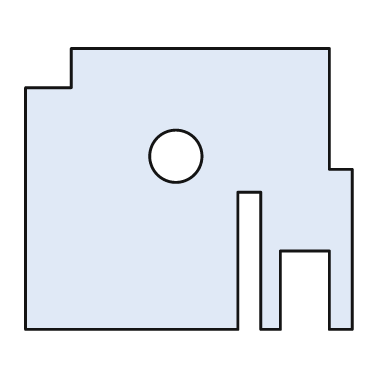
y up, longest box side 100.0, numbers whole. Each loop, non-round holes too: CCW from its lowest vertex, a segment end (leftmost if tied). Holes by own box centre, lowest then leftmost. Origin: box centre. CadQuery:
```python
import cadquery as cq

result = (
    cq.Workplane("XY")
    .moveTo(-50.0, -43.0)
    .lineTo(15.0, -43.0)
    .lineTo(15.0, -1.0)
    .lineTo(22.0, -1.0)
    .lineTo(22.0, -43.0)
    .lineTo(28.0, -43.0)
    .lineTo(28.0, -19.0)
    .lineTo(43.0, -19.0)
    .lineTo(43.0, -43.0)
    .lineTo(50.0, -43.0)
    .lineTo(50.0, 6.0)
    .lineTo(43.0, 6.0)
    .lineTo(43.0, 43.0)
    .lineTo(-36.0, 43.0)
    .lineTo(-36.0, 31.0)
    .lineTo(-50.0, 31.0)
    .close()
    .moveTo(-4.0, 10.0)
    .circle(8.0)
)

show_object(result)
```